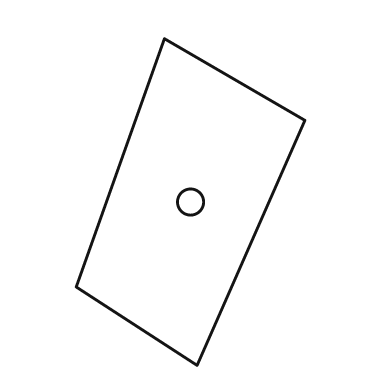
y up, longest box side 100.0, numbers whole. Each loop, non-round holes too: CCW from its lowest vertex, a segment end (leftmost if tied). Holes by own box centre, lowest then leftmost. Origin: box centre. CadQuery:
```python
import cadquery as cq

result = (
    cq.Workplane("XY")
    .moveTo(2.0, -50.0)
    .lineTo(35.0, 25.0)
    .lineTo(-8.0, 50.0)
    .lineTo(-35.0, -26.0)
    .close()
    .moveTo(0.0, 0.0)
    .circle(4.0)
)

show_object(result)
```